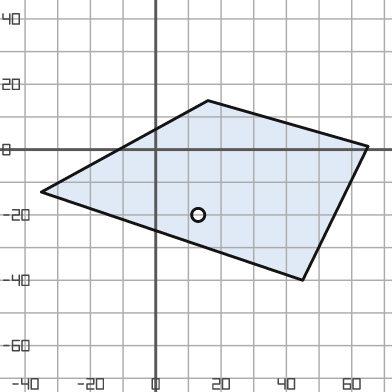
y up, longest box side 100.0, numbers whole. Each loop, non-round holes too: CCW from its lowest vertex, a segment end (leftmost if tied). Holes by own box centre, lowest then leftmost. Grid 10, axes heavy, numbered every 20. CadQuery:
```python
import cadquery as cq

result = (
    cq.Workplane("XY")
    .moveTo(45.0, -40.0)
    .lineTo(65.0, 1.0)
    .lineTo(16.0, 15.0)
    .lineTo(-35.0, -13.0)
    .close()
    .moveTo(13.0, -20.0)
    .circle(2.0)
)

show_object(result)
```